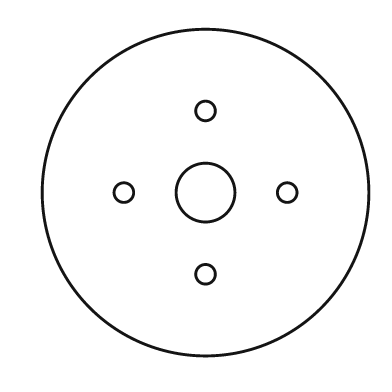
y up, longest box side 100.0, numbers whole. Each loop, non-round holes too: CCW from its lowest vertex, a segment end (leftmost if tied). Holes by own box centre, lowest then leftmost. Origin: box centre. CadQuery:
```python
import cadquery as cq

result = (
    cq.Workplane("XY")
    .moveTo(0.0, 0.0)
    .circle(50.0)
    .moveTo(0.0, -25.0)
    .circle(3.0)
    .moveTo(-25.0, 0.0)
    .circle(3.0)
    .moveTo(0.0, 0.0)
    .circle(9.0)
    .moveTo(25.0, 0.0)
    .circle(3.0)
    .moveTo(0.0, 25.0)
    .circle(3.0)
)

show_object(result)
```